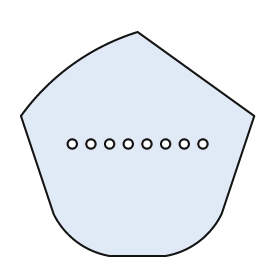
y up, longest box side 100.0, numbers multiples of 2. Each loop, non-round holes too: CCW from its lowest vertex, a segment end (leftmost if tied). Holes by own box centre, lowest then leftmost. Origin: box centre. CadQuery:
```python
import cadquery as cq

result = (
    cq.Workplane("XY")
    .moveTo(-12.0, -48.0)
    .lineTo(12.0, -48.0)
    .threePointArc((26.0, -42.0), (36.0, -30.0))
    .lineTo(50.0, 12.0)
    .lineTo(0.0, 48.0)
    .threePointArc((-28.0, 34.0), (-50.0, 12.0))
    .lineTo(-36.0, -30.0)
    .threePointArc((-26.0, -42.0), (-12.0, -48.0))
    .close()
    .moveTo(-28.0, 0.0)
    .circle(2.0)
    .moveTo(-20.0, 0.0)
    .circle(2.0)
    .moveTo(-12.0, 0.0)
    .circle(2.0)
    .moveTo(-4.0, 0.0)
    .circle(2.0)
    .moveTo(4.0, 0.0)
    .circle(2.0)
    .moveTo(12.0, 0.0)
    .circle(2.0)
    .moveTo(20.0, 0.0)
    .circle(2.0)
    .moveTo(28.0, 0.0)
    .circle(2.0)
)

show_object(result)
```